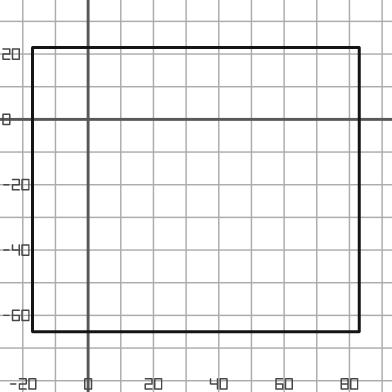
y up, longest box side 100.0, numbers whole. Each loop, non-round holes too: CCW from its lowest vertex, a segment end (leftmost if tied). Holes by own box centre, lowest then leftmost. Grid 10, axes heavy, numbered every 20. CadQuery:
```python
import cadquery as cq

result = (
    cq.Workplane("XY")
    .moveTo(-17.0, -65.0)
    .lineTo(83.0, -65.0)
    .lineTo(83.0, 22.0)
    .lineTo(-17.0, 22.0)
    .close()
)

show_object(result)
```